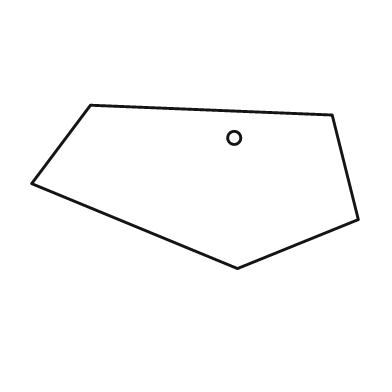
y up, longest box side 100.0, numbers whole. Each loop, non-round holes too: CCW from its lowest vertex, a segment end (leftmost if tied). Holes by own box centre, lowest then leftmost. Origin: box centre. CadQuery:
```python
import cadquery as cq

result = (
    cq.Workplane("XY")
    .moveTo(13.0, -25.0)
    .lineTo(50.0, -10.0)
    .lineTo(42.0, 22.0)
    .lineTo(-32.0, 25.0)
    .lineTo(-50.0, 1.0)
    .close()
    .moveTo(12.0, 15.0)
    .circle(2.0)
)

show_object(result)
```